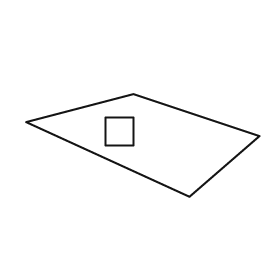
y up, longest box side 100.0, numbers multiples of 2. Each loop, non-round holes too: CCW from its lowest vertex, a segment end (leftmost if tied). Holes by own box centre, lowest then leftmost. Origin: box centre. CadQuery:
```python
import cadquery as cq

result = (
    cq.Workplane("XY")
    .moveTo(20.0, -22.0)
    .lineTo(50.0, 4.0)
    .lineTo(-4.0, 22.0)
    .lineTo(-50.0, 10.0)
    .close()
    .moveTo(-16.0, 0.0)
    .lineTo(-4.0, 0.0)
    .lineTo(-4.0, 12.0)
    .lineTo(-16.0, 12.0)
    .close()
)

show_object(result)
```